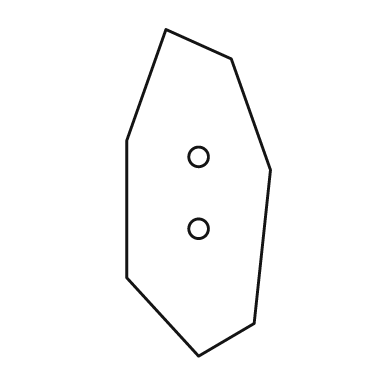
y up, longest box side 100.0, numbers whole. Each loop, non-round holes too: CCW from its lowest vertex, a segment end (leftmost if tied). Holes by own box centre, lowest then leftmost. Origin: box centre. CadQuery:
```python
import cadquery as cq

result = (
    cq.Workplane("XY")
    .moveTo(0.0, -50.0)
    .lineTo(17.0, -40.0)
    .lineTo(22.0, 7.0)
    .lineTo(10.0, 41.0)
    .lineTo(-10.0, 50.0)
    .lineTo(-22.0, 16.0)
    .lineTo(-22.0, -26.0)
    .close()
    .moveTo(0.0, -11.0)
    .circle(3.0)
    .moveTo(0.0, 11.0)
    .circle(3.0)
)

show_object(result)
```